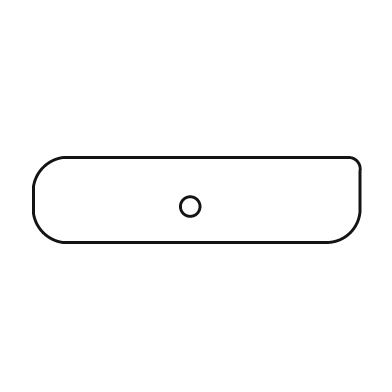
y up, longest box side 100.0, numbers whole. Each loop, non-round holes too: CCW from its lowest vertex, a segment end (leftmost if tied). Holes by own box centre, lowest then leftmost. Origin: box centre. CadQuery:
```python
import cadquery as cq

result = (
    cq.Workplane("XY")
    .moveTo(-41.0, -13.0)
    .lineTo(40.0, -13.0)
    .threePointArc((47.0, -10.0), (50.0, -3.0))
    .lineTo(50.0, 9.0)
    .threePointArc((49.0, 12.0), (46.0, 13.0))
    .lineTo(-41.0, 13.0)
    .threePointArc((-47.0, 10.0), (-50.0, 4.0))
    .lineTo(-50.0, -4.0)
    .threePointArc((-47.0, -10.0), (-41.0, -13.0))
    .close()
    .moveTo(-2.0, -2.0)
    .circle(3.0)
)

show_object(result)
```